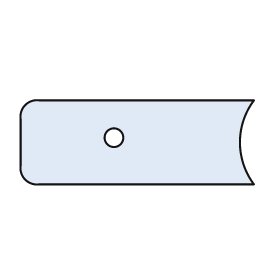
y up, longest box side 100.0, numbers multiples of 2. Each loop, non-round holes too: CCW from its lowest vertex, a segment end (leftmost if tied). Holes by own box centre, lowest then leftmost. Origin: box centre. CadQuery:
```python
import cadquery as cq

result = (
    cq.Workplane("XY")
    .moveTo(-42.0, -18.0)
    .lineTo(50.0, -18.0)
    .threePointArc((44.0, 0.0), (50.0, 18.0))
    .lineTo(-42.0, 18.0)
    .threePointArc((-48.0, 16.0), (-50.0, 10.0))
    .lineTo(-50.0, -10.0)
    .threePointArc((-48.0, -16.0), (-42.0, -18.0))
    .close()
    .moveTo(-10.0, 2.0)
    .circle(4.0)
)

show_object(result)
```